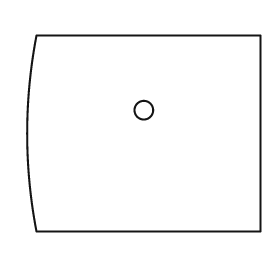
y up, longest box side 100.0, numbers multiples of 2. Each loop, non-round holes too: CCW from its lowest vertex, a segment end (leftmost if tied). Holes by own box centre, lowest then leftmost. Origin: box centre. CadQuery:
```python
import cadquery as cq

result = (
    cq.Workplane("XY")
    .moveTo(-46.0, -42.0)
    .lineTo(50.0, -42.0)
    .lineTo(50.0, 42.0)
    .lineTo(-46.0, 42.0)
    .threePointArc((-50.0, 0.0), (-46.0, -42.0))
    .close()
    .moveTo(0.0, 10.0)
    .circle(4.0)
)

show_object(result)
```